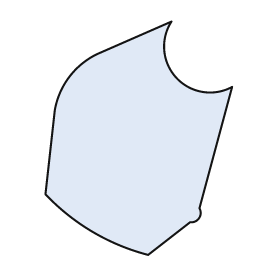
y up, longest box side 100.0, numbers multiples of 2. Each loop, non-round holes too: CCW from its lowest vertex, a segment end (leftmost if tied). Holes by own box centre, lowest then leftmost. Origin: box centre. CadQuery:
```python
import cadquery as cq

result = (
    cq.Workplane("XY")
    .moveTo(4.0, -50.0)
    .lineTo(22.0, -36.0)
    .threePointArc((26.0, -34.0), (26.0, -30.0))
    .lineTo(40.0, 22.0)
    .threePointArc((16.0, 26.0), (14.0, 50.0))
    .lineTo(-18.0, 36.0)
    .threePointArc((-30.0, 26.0), (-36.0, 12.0))
    .lineTo(-40.0, -24.0)
    .threePointArc((-20.0, -40.0), (4.0, -50.0))
    .close()
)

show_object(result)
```